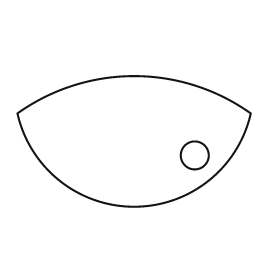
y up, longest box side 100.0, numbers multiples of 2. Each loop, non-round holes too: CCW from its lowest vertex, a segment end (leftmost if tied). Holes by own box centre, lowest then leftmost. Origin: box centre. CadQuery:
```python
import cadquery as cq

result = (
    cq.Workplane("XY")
    .moveTo(-50.0, 12.0)
    .threePointArc((0.0, -28.0), (50.0, 12.0))
    .threePointArc((0.0, 28.0), (-50.0, 12.0))
    .close()
    .moveTo(26.0, -6.0)
    .circle(6.0)
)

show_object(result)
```